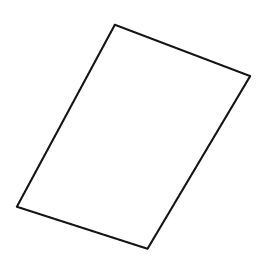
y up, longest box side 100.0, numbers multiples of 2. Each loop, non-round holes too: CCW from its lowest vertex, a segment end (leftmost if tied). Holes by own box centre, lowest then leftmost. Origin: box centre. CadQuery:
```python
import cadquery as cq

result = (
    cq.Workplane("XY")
    .moveTo(6.0, -48.0)
    .lineTo(50.0, 26.0)
    .lineTo(-8.0, 48.0)
    .lineTo(-50.0, -30.0)
    .close()
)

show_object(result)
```